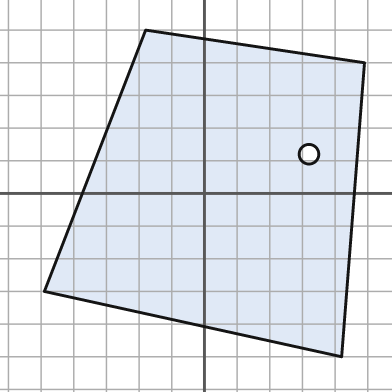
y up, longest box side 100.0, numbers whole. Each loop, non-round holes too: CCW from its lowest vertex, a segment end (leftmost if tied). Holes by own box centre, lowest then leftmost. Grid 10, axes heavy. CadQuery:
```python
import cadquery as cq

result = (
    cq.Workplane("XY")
    .moveTo(42.0, -50.0)
    .lineTo(49.0, 40.0)
    .lineTo(-18.0, 50.0)
    .lineTo(-49.0, -30.0)
    .close()
    .moveTo(32.0, 12.0)
    .circle(3.0)
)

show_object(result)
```